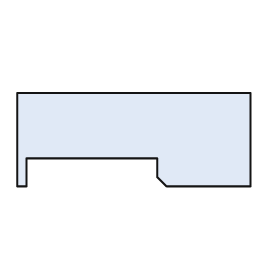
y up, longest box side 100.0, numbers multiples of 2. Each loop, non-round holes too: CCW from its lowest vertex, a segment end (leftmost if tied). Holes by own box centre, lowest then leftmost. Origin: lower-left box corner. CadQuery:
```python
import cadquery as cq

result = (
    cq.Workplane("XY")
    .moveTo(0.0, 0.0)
    .lineTo(4.0, 0.0)
    .lineTo(4.0, 12.0)
    .lineTo(60.0, 12.0)
    .lineTo(60.0, 4.0)
    .lineTo(64.0, 0.0)
    .lineTo(100.0, 0.0)
    .lineTo(100.0, 40.0)
    .lineTo(0.0, 40.0)
    .close()
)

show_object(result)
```